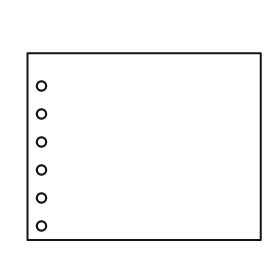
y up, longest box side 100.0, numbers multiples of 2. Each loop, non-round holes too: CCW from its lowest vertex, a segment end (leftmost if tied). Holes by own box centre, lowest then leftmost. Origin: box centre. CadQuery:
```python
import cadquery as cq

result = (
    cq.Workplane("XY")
    .moveTo(-50.0, -40.0)
    .lineTo(50.0, -40.0)
    .lineTo(50.0, 40.0)
    .lineTo(-50.0, 40.0)
    .close()
    .moveTo(-44.0, -34.0)
    .circle(2.0)
    .moveTo(-44.0, -22.0)
    .circle(2.0)
    .moveTo(-44.0, -10.0)
    .circle(2.0)
    .moveTo(-44.0, 2.0)
    .circle(2.0)
    .moveTo(-44.0, 14.0)
    .circle(2.0)
    .moveTo(-44.0, 26.0)
    .circle(2.0)
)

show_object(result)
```